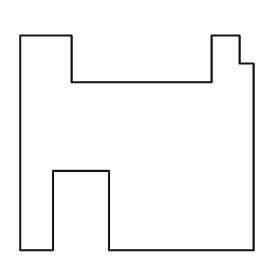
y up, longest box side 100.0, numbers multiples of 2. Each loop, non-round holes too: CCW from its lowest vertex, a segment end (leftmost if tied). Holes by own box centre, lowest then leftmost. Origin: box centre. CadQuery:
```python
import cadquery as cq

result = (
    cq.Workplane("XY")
    .moveTo(-50.0, -46.0)
    .lineTo(-36.0, -46.0)
    .lineTo(-36.0, -12.0)
    .lineTo(-12.0, -12.0)
    .lineTo(-12.0, -46.0)
    .lineTo(50.0, -46.0)
    .lineTo(50.0, 34.0)
    .lineTo(44.0, 34.0)
    .lineTo(44.0, 46.0)
    .lineTo(32.0, 46.0)
    .lineTo(32.0, 26.0)
    .lineTo(-28.0, 26.0)
    .lineTo(-28.0, 46.0)
    .lineTo(-50.0, 46.0)
    .close()
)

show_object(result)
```